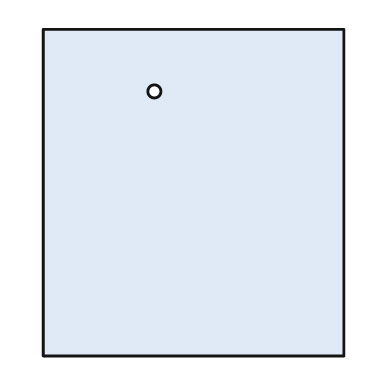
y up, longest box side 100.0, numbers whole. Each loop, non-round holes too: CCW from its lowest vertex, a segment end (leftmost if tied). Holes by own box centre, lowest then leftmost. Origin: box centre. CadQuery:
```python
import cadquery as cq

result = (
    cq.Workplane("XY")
    .moveTo(-46.0, -50.0)
    .lineTo(46.0, -50.0)
    .lineTo(46.0, 50.0)
    .lineTo(-46.0, 50.0)
    .close()
    .moveTo(-12.0, 31.0)
    .circle(2.0)
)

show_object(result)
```